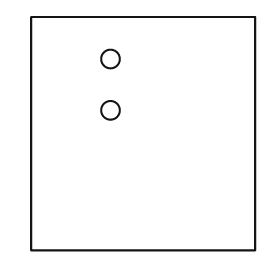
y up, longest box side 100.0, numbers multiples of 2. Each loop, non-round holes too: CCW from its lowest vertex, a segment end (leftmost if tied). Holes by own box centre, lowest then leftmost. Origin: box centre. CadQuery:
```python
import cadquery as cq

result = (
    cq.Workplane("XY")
    .moveTo(-48.0, -50.0)
    .lineTo(48.0, -50.0)
    .lineTo(48.0, 50.0)
    .lineTo(-48.0, 50.0)
    .close()
    .moveTo(-14.0, 10.0)
    .circle(4.0)
    .moveTo(-14.0, 32.0)
    .circle(4.0)
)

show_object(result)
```